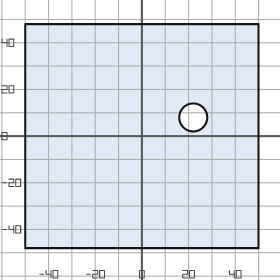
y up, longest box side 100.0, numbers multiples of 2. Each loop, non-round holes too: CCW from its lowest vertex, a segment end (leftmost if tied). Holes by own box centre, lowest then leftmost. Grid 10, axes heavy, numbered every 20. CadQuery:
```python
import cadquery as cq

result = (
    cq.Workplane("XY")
    .moveTo(-50.0, -48.0)
    .lineTo(50.0, -48.0)
    .lineTo(50.0, 48.0)
    .lineTo(-50.0, 48.0)
    .close()
    .moveTo(22.0, 8.0)
    .circle(6.0)
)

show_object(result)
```